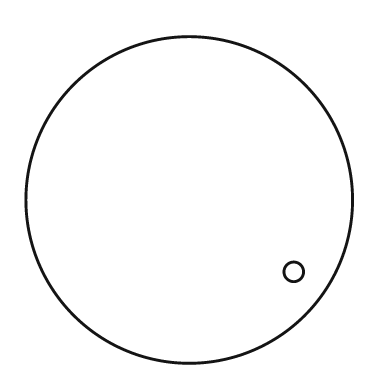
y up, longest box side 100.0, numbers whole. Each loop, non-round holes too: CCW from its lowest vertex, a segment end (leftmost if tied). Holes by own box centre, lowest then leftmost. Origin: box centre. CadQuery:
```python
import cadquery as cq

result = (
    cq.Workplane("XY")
    .moveTo(0.0, 0.0)
    .circle(50.0)
    .moveTo(32.0, -22.0)
    .circle(3.0)
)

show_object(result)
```